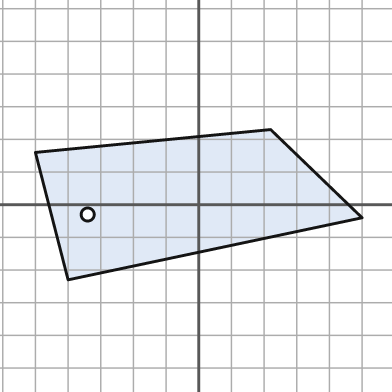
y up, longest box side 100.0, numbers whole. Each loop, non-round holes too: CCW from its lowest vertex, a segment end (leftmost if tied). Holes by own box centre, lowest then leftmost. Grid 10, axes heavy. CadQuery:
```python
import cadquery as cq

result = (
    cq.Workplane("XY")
    .moveTo(-40.0, -23.0)
    .lineTo(50.0, -4.0)
    .lineTo(22.0, 23.0)
    .lineTo(-50.0, 16.0)
    .close()
    .moveTo(-34.0, -3.0)
    .circle(2.0)
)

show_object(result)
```